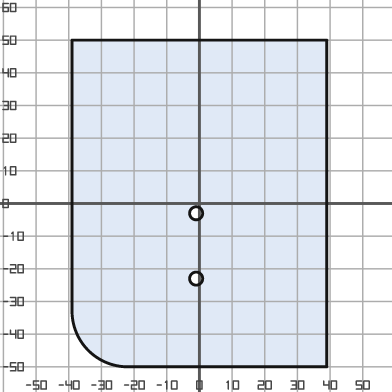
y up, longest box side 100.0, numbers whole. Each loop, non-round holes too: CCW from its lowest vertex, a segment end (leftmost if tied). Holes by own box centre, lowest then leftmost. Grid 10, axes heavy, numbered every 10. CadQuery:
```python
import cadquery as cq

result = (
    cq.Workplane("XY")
    .moveTo(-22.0, -50.0)
    .lineTo(39.0, -50.0)
    .lineTo(39.0, 50.0)
    .lineTo(-39.0, 50.0)
    .lineTo(-39.0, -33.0)
    .threePointArc((-34.0, -45.0), (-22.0, -50.0))
    .close()
    .moveTo(-1.0, -23.0)
    .circle(2.0)
    .moveTo(-1.0, -3.0)
    .circle(2.0)
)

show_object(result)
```